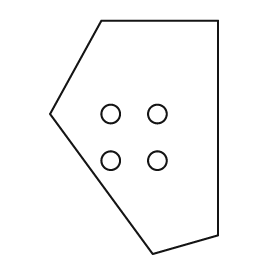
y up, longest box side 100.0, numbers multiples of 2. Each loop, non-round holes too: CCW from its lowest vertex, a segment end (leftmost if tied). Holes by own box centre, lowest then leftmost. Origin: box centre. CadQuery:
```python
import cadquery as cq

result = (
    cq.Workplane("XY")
    .moveTo(8.0, -50.0)
    .lineTo(36.0, -42.0)
    .lineTo(36.0, 50.0)
    .lineTo(-14.0, 50.0)
    .lineTo(-36.0, 10.0)
    .close()
    .moveTo(-10.0, -10.0)
    .circle(4.0)
    .moveTo(10.0, -10.0)
    .circle(4.0)
    .moveTo(-10.0, 10.0)
    .circle(4.0)
    .moveTo(10.0, 10.0)
    .circle(4.0)
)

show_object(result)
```